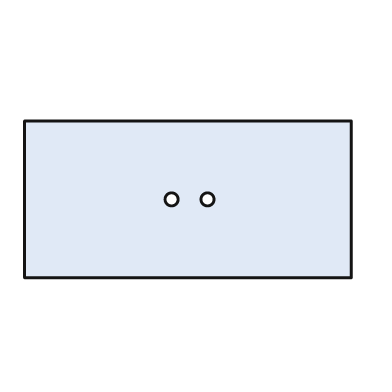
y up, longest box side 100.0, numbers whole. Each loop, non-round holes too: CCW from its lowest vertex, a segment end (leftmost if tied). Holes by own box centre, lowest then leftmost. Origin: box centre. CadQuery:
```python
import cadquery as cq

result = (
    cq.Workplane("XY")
    .moveTo(-50.0, -24.0)
    .lineTo(50.0, -24.0)
    .lineTo(50.0, 24.0)
    .lineTo(-50.0, 24.0)
    .close()
    .moveTo(-5.0, 0.0)
    .circle(2.0)
    .moveTo(6.0, 0.0)
    .circle(2.0)
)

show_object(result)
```